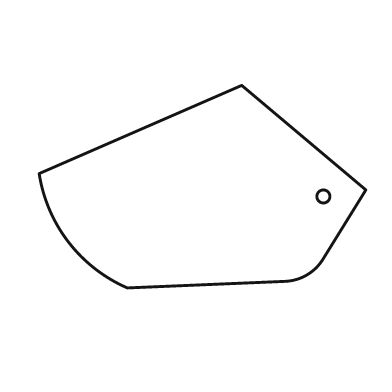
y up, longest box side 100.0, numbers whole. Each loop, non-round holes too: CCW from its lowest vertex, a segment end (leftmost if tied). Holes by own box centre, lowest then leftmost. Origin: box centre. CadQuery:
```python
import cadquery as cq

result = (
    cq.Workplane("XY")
    .moveTo(-23.0, -31.0)
    .lineTo(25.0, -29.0)
    .threePointArc((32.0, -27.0), (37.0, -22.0))
    .lineTo(50.0, -1.0)
    .lineTo(12.0, 31.0)
    .lineTo(-50.0, 4.0)
    .threePointArc((-41.0, -17.0), (-23.0, -31.0))
    .close()
    .moveTo(37.0, -3.0)
    .circle(2.0)
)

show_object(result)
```